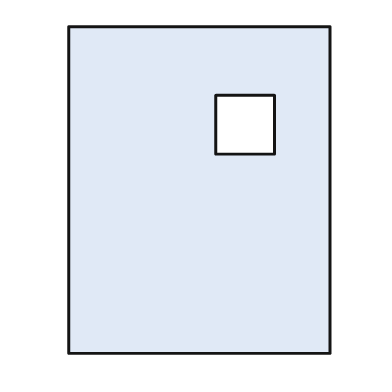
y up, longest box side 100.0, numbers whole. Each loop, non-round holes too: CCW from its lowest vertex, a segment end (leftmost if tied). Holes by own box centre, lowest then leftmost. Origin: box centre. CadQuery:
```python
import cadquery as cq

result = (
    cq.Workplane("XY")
    .moveTo(-40.0, -50.0)
    .lineTo(40.0, -50.0)
    .lineTo(40.0, 50.0)
    .lineTo(-40.0, 50.0)
    .close()
    .moveTo(5.0, 11.0)
    .lineTo(23.0, 11.0)
    .lineTo(23.0, 29.0)
    .lineTo(5.0, 29.0)
    .close()
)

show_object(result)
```